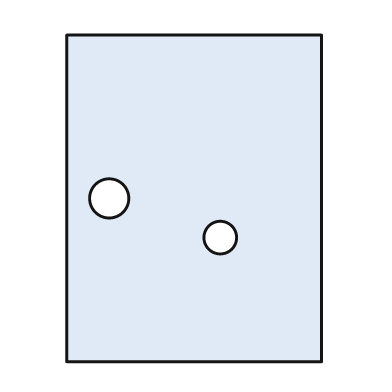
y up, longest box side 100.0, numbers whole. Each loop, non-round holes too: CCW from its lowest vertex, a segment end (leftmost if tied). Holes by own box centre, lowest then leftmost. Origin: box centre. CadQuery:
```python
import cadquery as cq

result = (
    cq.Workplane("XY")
    .moveTo(-39.0, -50.0)
    .lineTo(39.0, -50.0)
    .lineTo(39.0, 50.0)
    .lineTo(-39.0, 50.0)
    .close()
    .moveTo(8.0, -12.0)
    .circle(5.0)
    .moveTo(-26.0, 0.0)
    .circle(6.0)
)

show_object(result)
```